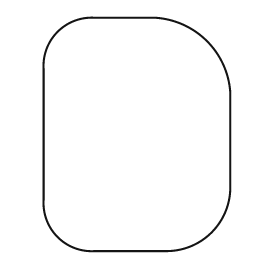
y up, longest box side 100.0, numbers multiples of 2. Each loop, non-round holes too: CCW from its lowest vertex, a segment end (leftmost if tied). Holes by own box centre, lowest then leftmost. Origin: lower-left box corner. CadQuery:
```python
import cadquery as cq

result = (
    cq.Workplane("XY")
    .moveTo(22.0, 0.0)
    .lineTo(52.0, 0.0)
    .threePointArc((72.0, 8.0), (80.0, 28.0))
    .lineTo(80.0, 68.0)
    .threePointArc((70.0, 90.0), (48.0, 100.0))
    .lineTo(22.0, 100.0)
    .threePointArc((6.0, 94.0), (0.0, 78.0))
    .lineTo(0.0, 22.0)
    .threePointArc((6.0, 6.0), (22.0, 0.0))
    .close()
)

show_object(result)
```